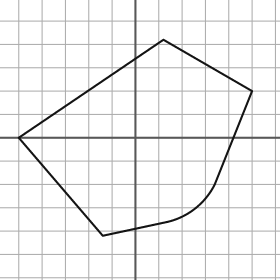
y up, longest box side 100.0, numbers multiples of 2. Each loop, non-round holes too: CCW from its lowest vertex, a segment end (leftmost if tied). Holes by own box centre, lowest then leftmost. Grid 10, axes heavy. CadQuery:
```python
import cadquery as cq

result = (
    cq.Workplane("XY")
    .moveTo(-14.0, -42.0)
    .lineTo(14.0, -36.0)
    .threePointArc((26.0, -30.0), (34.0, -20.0))
    .lineTo(50.0, 20.0)
    .lineTo(12.0, 42.0)
    .lineTo(-50.0, 0.0)
    .close()
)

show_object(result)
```